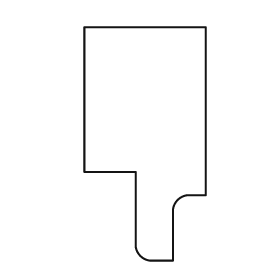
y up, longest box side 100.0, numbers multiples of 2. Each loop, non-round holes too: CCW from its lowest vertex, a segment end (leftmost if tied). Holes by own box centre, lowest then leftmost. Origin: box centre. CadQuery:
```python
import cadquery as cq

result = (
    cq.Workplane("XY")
    .moveTo(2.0, -50.0)
    .lineTo(12.0, -50.0)
    .lineTo(12.0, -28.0)
    .threePointArc((14.0, -24.0), (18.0, -22.0))
    .lineTo(26.0, -22.0)
    .lineTo(26.0, 50.0)
    .lineTo(-26.0, 50.0)
    .lineTo(-26.0, -12.0)
    .lineTo(-4.0, -12.0)
    .lineTo(-4.0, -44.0)
    .threePointArc((-2.0, -48.0), (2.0, -50.0))
    .close()
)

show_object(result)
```